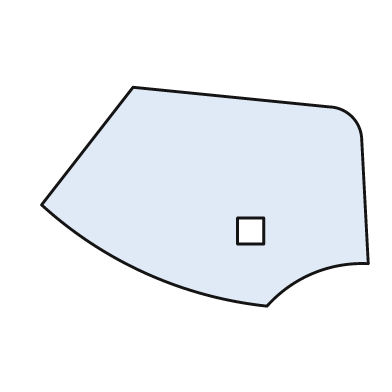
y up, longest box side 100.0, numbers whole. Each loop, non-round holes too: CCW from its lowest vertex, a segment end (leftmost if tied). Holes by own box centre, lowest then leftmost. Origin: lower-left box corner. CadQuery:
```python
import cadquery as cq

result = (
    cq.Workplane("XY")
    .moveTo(69.0, 0.0)
    .threePointArc((83.0, 10.0), (100.0, 13.0))
    .lineTo(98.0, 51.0)
    .threePointArc((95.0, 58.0), (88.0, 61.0))
    .lineTo(28.0, 67.0)
    .lineTo(0.0, 31.0)
    .threePointArc((32.0, 10.0), (69.0, 0.0))
    .close()
    .moveTo(60.0, 19.0)
    .lineTo(68.0, 19.0)
    .lineTo(68.0, 27.0)
    .lineTo(60.0, 27.0)
    .close()
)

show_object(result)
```